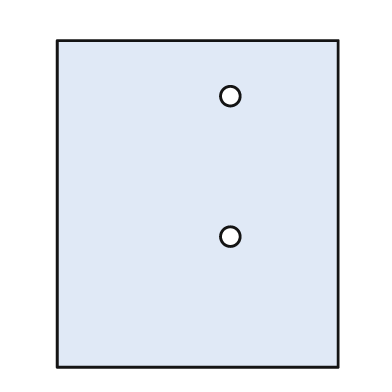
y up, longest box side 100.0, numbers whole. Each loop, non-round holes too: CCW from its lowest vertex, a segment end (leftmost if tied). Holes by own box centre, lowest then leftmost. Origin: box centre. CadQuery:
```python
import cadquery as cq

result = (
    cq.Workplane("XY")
    .moveTo(-43.0, -50.0)
    .lineTo(43.0, -50.0)
    .lineTo(43.0, 50.0)
    .lineTo(-43.0, 50.0)
    .close()
    .moveTo(10.0, -10.0)
    .circle(3.0)
    .moveTo(10.0, 33.0)
    .circle(3.0)
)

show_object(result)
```